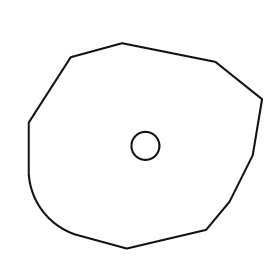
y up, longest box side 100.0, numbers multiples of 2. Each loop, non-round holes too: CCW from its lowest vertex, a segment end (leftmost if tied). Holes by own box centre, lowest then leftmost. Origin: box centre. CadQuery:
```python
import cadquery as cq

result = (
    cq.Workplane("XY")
    .moveTo(-8.0, -44.0)
    .lineTo(26.0, -36.0)
    .lineTo(36.0, -24.0)
    .lineTo(46.0, -4.0)
    .lineTo(50.0, 20.0)
    .lineTo(30.0, 36.0)
    .lineTo(-10.0, 44.0)
    .lineTo(-32.0, 38.0)
    .lineTo(-50.0, 10.0)
    .lineTo(-50.0, -12.0)
    .threePointArc((-44.0, -28.0), (-30.0, -38.0))
    .close()
    .moveTo(0.0, 0.0)
    .circle(6.0)
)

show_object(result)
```